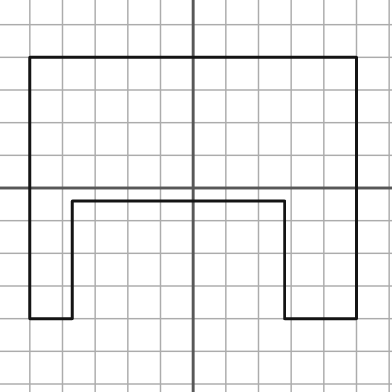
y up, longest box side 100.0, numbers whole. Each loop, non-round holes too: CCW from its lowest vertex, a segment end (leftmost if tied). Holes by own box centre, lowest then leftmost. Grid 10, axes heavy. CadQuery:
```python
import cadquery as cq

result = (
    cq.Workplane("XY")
    .moveTo(-50.0, -40.0)
    .lineTo(-37.0, -40.0)
    .lineTo(-37.0, -4.0)
    .lineTo(28.0, -4.0)
    .lineTo(28.0, -40.0)
    .lineTo(50.0, -40.0)
    .lineTo(50.0, 40.0)
    .lineTo(-50.0, 40.0)
    .close()
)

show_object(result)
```